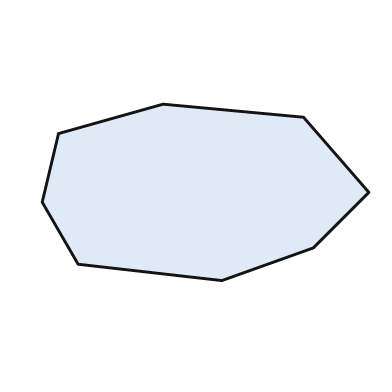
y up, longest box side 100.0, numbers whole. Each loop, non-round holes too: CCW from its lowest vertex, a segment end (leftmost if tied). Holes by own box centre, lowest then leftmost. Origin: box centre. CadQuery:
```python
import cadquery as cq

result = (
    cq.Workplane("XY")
    .moveTo(5.0, -27.0)
    .lineTo(33.0, -17.0)
    .lineTo(50.0, 0.0)
    .lineTo(30.0, 23.0)
    .lineTo(-13.0, 27.0)
    .lineTo(-45.0, 18.0)
    .lineTo(-50.0, -3.0)
    .lineTo(-39.0, -22.0)
    .close()
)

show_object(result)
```